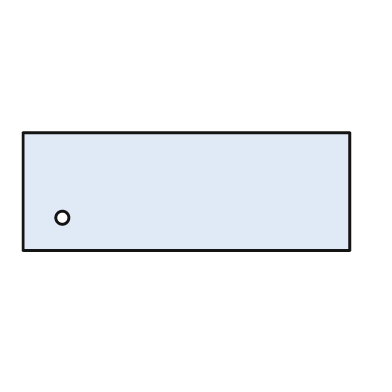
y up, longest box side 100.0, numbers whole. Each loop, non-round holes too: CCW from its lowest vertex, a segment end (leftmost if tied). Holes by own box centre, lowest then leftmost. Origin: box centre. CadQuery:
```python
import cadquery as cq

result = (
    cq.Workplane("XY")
    .moveTo(-50.0, -18.0)
    .lineTo(50.0, -18.0)
    .lineTo(50.0, 18.0)
    .lineTo(-50.0, 18.0)
    .close()
    .moveTo(-38.0, -8.0)
    .circle(2.0)
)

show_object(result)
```